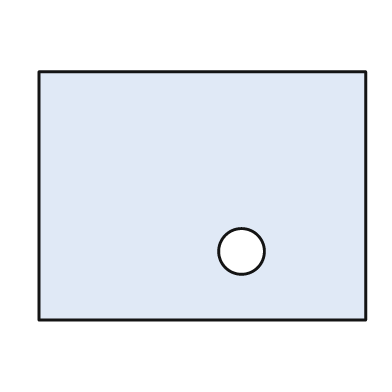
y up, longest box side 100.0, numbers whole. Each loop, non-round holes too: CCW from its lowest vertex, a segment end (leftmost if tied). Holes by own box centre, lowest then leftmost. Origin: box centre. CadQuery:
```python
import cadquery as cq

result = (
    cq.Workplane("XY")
    .moveTo(-50.0, -38.0)
    .lineTo(50.0, -38.0)
    .lineTo(50.0, 38.0)
    .lineTo(-50.0, 38.0)
    .close()
    .moveTo(12.0, -17.0)
    .circle(7.0)
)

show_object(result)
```